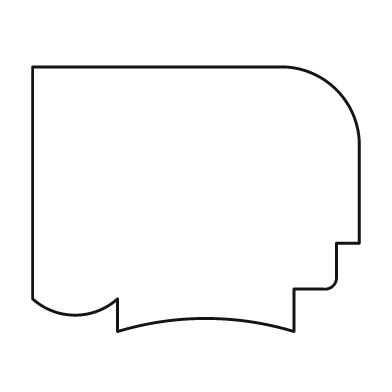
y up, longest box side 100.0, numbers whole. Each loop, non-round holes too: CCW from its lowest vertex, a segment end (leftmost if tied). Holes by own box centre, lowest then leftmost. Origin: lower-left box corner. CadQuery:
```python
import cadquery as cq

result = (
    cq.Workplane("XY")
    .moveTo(26.0, 0.0)
    .threePointArc((53.0, 4.0), (80.0, 0.0))
    .lineTo(80.0, 13.0)
    .lineTo(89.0, 13.0)
    .threePointArc((92.0, 14.0), (93.0, 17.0))
    .lineTo(93.0, 27.0)
    .lineTo(100.0, 27.0)
    .lineTo(100.0, 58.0)
    .threePointArc((93.0, 74.0), (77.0, 81.0))
    .lineTo(0.0, 81.0)
    .lineTo(0.0, 10.0)
    .threePointArc((13.0, 5.0), (26.0, 10.0))
    .close()
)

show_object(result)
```